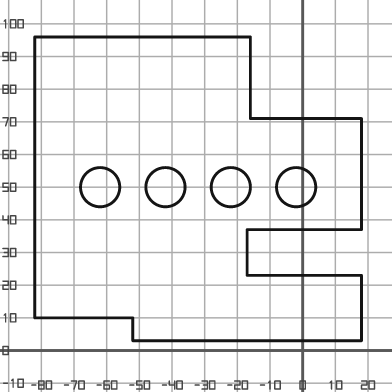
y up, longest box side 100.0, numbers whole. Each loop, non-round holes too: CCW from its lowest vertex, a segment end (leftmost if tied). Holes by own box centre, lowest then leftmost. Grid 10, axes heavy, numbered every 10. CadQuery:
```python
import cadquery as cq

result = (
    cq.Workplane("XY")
    .moveTo(-52.0, 3.0)
    .lineTo(18.0, 3.0)
    .lineTo(18.0, 23.0)
    .lineTo(-17.0, 23.0)
    .lineTo(-17.0, 37.0)
    .lineTo(18.0, 37.0)
    .lineTo(18.0, 71.0)
    .lineTo(-16.0, 71.0)
    .lineTo(-16.0, 96.0)
    .lineTo(-82.0, 96.0)
    .lineTo(-82.0, 10.0)
    .lineTo(-52.0, 10.0)
    .close()
    .moveTo(-62.0, 50.0)
    .circle(6.0)
    .moveTo(-42.0, 50.0)
    .circle(6.0)
    .moveTo(-22.0, 50.0)
    .circle(6.0)
    .moveTo(-2.0, 50.0)
    .circle(6.0)
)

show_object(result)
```